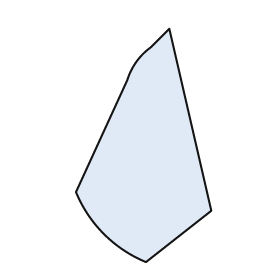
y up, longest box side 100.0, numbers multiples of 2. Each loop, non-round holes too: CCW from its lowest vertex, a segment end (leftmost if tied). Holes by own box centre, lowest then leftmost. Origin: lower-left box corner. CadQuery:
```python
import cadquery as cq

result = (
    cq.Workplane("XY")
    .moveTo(30.0, 0.0)
    .lineTo(58.0, 22.0)
    .lineTo(40.0, 100.0)
    .lineTo(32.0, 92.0)
    .threePointArc((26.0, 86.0), (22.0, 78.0))
    .lineTo(0.0, 30.0)
    .threePointArc((12.0, 12.0), (30.0, 0.0))
    .close()
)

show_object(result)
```